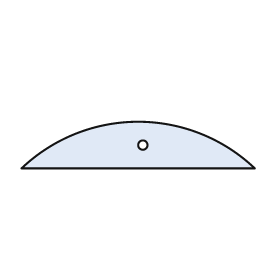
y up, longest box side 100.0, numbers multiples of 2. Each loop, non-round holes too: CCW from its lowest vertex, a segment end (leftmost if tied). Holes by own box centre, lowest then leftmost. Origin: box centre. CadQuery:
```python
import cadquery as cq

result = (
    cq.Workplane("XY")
    .moveTo(-50.0, -10.0)
    .lineTo(50.0, -10.0)
    .threePointArc((0.0, 10.0), (-50.0, -10.0))
    .close()
    .moveTo(2.0, 0.0)
    .circle(2.0)
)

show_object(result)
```